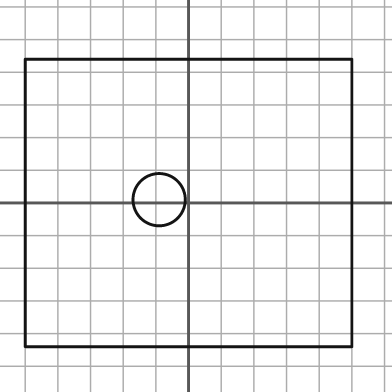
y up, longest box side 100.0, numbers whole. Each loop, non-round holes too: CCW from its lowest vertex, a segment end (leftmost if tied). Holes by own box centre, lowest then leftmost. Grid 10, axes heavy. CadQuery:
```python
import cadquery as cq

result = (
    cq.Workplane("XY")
    .moveTo(-50.0, -44.0)
    .lineTo(50.0, -44.0)
    .lineTo(50.0, 44.0)
    .lineTo(-50.0, 44.0)
    .close()
    .moveTo(-9.0, 1.0)
    .circle(8.0)
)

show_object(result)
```